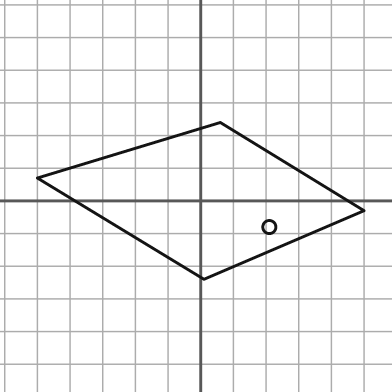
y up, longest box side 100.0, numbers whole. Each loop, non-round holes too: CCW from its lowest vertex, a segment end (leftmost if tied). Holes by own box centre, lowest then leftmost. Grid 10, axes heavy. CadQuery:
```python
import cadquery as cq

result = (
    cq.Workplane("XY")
    .moveTo(1.0, -24.0)
    .lineTo(50.0, -3.0)
    .lineTo(6.0, 24.0)
    .lineTo(-50.0, 7.0)
    .close()
    .moveTo(21.0, -8.0)
    .circle(2.0)
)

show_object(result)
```